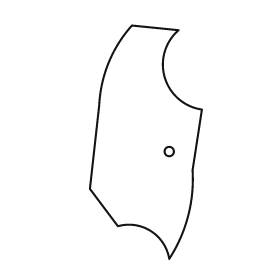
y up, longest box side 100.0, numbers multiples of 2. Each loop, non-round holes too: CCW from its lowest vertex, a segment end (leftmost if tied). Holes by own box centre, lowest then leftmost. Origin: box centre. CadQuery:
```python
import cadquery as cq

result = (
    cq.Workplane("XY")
    .moveTo(10.0, -50.0)
    .threePointArc((18.0, -32.0), (20.0, -12.0))
    .lineTo(24.0, 14.0)
    .threePointArc((8.0, 28.0), (14.0, 48.0))
    .lineTo(-6.0, 50.0)
    .threePointArc((-16.0, 34.0), (-20.0, 16.0))
    .lineTo(-24.0, -20.0)
    .lineTo(-12.0, -36.0)
    .threePointArc((2.0, -38.0), (10.0, -50.0))
    .close()
    .moveTo(10.0, -4.0)
    .circle(2.0)
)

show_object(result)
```